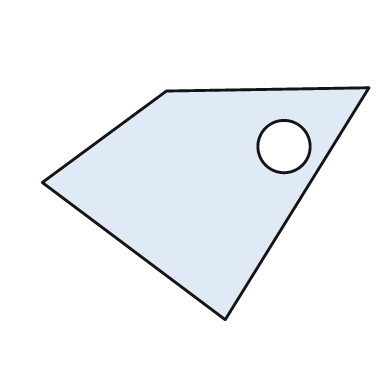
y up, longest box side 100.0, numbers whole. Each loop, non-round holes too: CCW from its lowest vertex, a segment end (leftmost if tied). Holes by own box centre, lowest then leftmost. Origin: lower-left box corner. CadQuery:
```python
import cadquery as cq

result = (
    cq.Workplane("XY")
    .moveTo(56.0, 0.0)
    .lineTo(100.0, 71.0)
    .lineTo(38.0, 70.0)
    .lineTo(0.0, 42.0)
    .close()
    .moveTo(74.0, 53.0)
    .circle(8.0)
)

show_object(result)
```